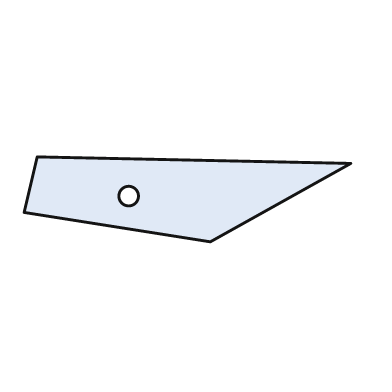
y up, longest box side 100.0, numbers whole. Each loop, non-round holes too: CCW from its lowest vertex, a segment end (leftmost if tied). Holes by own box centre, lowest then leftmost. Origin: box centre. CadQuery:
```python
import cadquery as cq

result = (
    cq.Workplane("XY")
    .moveTo(7.0, -13.0)
    .lineTo(50.0, 11.0)
    .lineTo(-46.0, 13.0)
    .lineTo(-50.0, -4.0)
    .close()
    .moveTo(-18.0, 1.0)
    .circle(3.0)
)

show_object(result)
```